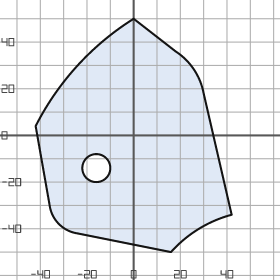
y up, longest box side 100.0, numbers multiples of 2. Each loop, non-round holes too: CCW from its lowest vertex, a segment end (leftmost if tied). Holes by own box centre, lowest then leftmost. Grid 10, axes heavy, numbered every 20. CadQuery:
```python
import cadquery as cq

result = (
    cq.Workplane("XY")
    .moveTo(16.0, -50.0)
    .threePointArc((28.0, -40.0), (42.0, -34.0))
    .lineTo(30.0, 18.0)
    .threePointArc((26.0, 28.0), (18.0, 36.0))
    .lineTo(0.0, 50.0)
    .threePointArc((-24.0, 30.0), (-42.0, 4.0))
    .lineTo(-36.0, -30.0)
    .threePointArc((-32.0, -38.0), (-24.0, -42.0))
    .close()
    .moveTo(-16.0, -14.0)
    .circle(6.0)
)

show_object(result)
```